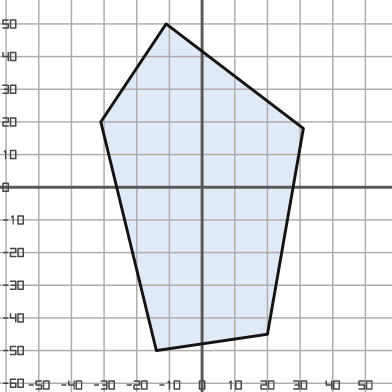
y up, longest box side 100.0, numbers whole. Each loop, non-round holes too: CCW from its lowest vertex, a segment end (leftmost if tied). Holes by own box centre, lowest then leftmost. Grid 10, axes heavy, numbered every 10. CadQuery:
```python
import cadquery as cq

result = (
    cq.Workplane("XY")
    .moveTo(-14.0, -50.0)
    .lineTo(20.0, -45.0)
    .lineTo(31.0, 18.0)
    .lineTo(-11.0, 50.0)
    .lineTo(-31.0, 20.0)
    .close()
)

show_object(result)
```